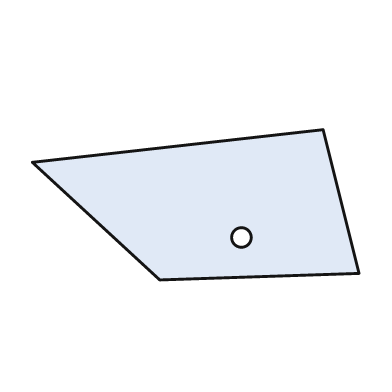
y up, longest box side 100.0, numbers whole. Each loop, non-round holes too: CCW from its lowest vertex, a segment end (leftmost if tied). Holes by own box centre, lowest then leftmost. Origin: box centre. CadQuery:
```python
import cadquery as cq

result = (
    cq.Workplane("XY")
    .moveTo(-11.0, -23.0)
    .lineTo(50.0, -21.0)
    .lineTo(39.0, 23.0)
    .lineTo(-50.0, 13.0)
    .close()
    .moveTo(14.0, -10.0)
    .circle(3.0)
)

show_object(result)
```